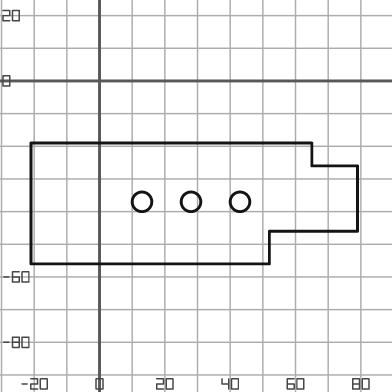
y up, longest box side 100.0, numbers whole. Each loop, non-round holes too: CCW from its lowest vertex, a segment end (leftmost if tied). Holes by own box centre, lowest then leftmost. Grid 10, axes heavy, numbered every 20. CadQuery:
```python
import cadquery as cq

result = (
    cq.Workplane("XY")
    .moveTo(-21.0, -56.0)
    .lineTo(52.0, -56.0)
    .lineTo(52.0, -46.0)
    .lineTo(79.0, -46.0)
    .lineTo(79.0, -26.0)
    .lineTo(65.0, -26.0)
    .lineTo(65.0, -19.0)
    .lineTo(-21.0, -19.0)
    .close()
    .moveTo(13.0, -37.0)
    .circle(3.0)
    .moveTo(28.0, -37.0)
    .circle(3.0)
    .moveTo(43.0, -37.0)
    .circle(3.0)
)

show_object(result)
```